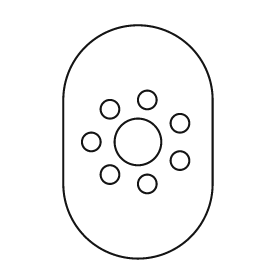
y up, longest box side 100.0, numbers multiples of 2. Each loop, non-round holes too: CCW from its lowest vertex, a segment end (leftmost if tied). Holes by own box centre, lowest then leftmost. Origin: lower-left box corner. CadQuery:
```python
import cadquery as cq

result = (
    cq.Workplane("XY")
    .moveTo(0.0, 32.0)
    .threePointArc((32.0, 0.0), (64.0, 32.0))
    .lineTo(64.0, 68.0)
    .threePointArc((32.0, 100.0), (0.0, 68.0))
    .close()
    .moveTo(36.0, 32.0)
    .circle(4.0)
    .moveTo(20.0, 36.0)
    .circle(4.0)
    .moveTo(50.0, 42.0)
    .circle(4.0)
    .moveTo(12.0, 50.0)
    .circle(4.0)
    .moveTo(32.0, 50.0)
    .circle(10.0)
    .moveTo(50.0, 58.0)
    .circle(4.0)
    .moveTo(20.0, 64.0)
    .circle(4.0)
    .moveTo(36.0, 68.0)
    .circle(4.0)
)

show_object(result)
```